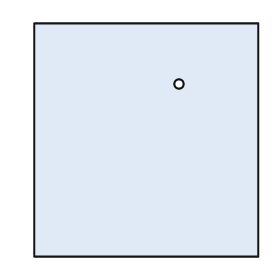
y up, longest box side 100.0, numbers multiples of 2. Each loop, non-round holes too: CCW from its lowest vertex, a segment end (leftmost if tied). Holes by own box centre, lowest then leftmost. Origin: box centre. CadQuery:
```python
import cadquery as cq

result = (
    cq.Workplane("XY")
    .moveTo(-48.0, -50.0)
    .lineTo(48.0, -50.0)
    .lineTo(48.0, 50.0)
    .lineTo(-48.0, 50.0)
    .close()
    .moveTo(14.0, 24.0)
    .circle(2.0)
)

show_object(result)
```